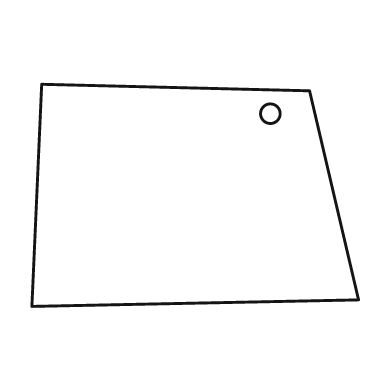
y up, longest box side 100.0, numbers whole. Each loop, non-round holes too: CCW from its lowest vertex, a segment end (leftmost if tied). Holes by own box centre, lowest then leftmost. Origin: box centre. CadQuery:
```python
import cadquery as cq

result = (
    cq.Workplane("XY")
    .moveTo(-50.0, -34.0)
    .lineTo(50.0, -32.0)
    .lineTo(35.0, 32.0)
    .lineTo(-47.0, 34.0)
    .close()
    .moveTo(23.0, 25.0)
    .circle(3.0)
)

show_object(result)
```